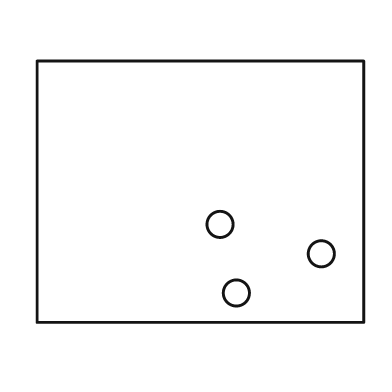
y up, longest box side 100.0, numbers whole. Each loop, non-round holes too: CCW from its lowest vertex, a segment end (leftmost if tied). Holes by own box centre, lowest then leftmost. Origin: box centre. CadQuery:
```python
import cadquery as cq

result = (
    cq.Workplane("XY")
    .moveTo(-50.0, -40.0)
    .lineTo(50.0, -40.0)
    .lineTo(50.0, 40.0)
    .lineTo(-50.0, 40.0)
    .close()
    .moveTo(11.0, -31.0)
    .circle(4.0)
    .moveTo(37.0, -19.0)
    .circle(4.0)
    .moveTo(6.0, -10.0)
    .circle(4.0)
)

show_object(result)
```